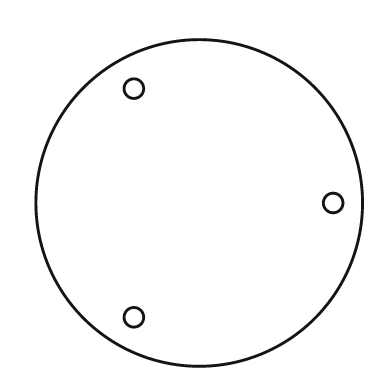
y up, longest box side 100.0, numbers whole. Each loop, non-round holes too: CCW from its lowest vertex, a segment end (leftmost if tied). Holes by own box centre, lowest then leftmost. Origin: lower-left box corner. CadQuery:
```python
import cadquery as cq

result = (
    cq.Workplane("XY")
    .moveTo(50.0, 50.0)
    .circle(50.0)
    .moveTo(30.0, 15.0)
    .circle(3.0)
    .moveTo(91.0, 50.0)
    .circle(3.0)
    .moveTo(30.0, 85.0)
    .circle(3.0)
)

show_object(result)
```